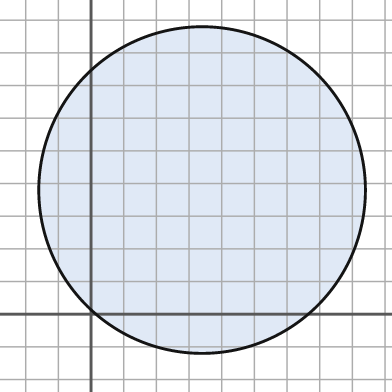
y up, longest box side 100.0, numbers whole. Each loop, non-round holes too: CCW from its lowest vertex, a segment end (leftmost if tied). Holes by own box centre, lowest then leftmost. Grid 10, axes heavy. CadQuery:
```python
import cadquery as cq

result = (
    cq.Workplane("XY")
    .moveTo(34.0, 38.0)
    .circle(50.0)
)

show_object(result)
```